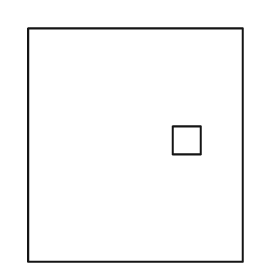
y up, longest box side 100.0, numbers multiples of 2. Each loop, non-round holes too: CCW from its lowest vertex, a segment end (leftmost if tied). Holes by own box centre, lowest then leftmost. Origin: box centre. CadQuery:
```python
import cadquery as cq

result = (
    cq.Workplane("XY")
    .moveTo(-46.0, -50.0)
    .lineTo(46.0, -50.0)
    .lineTo(46.0, 50.0)
    .lineTo(-46.0, 50.0)
    .close()
    .moveTo(16.0, -4.0)
    .lineTo(28.0, -4.0)
    .lineTo(28.0, 8.0)
    .lineTo(16.0, 8.0)
    .close()
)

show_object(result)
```